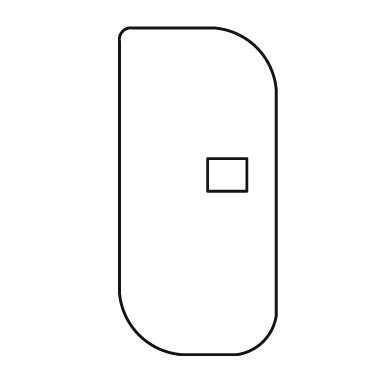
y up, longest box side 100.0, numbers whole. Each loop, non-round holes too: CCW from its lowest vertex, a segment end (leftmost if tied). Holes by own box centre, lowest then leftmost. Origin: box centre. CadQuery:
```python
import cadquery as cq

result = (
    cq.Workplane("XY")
    .moveTo(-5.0, -50.0)
    .lineTo(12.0, -50.0)
    .threePointArc((20.0, -46.0), (24.0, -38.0))
    .lineTo(24.0, 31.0)
    .threePointArc((18.0, 44.0), (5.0, 50.0))
    .lineTo(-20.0, 50.0)
    .threePointArc((-23.0, 49.0), (-24.0, 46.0))
    .lineTo(-24.0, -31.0)
    .threePointArc((-18.0, -44.0), (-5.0, -50.0))
    .close()
    .moveTo(3.0, 0.0)
    .lineTo(15.0, 0.0)
    .lineTo(15.0, 10.0)
    .lineTo(3.0, 10.0)
    .close()
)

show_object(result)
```